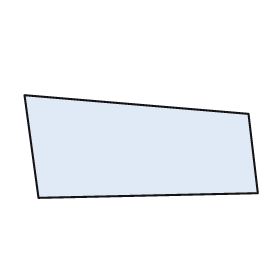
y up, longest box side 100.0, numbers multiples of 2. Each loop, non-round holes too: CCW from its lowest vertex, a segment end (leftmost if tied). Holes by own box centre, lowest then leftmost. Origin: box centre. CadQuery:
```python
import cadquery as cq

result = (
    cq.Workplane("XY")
    .moveTo(-44.0, -22.0)
    .lineTo(50.0, -20.0)
    .lineTo(46.0, 14.0)
    .lineTo(-50.0, 22.0)
    .close()
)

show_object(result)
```